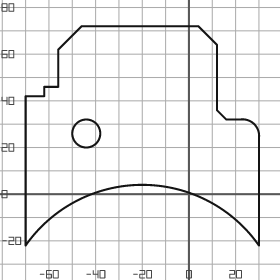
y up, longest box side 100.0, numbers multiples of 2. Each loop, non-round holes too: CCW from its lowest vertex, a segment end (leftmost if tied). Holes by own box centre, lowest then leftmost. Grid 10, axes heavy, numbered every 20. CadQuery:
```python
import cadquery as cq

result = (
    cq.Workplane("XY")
    .moveTo(-70.0, -22.0)
    .threePointArc((-20.0, 4.0), (30.0, -22.0))
    .lineTo(30.0, 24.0)
    .threePointArc((28.0, 30.0), (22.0, 32.0))
    .lineTo(16.0, 32.0)
    .lineTo(12.0, 36.0)
    .lineTo(12.0, 64.0)
    .lineTo(4.0, 72.0)
    .lineTo(-46.0, 72.0)
    .lineTo(-56.0, 62.0)
    .lineTo(-56.0, 46.0)
    .lineTo(-62.0, 46.0)
    .lineTo(-62.0, 42.0)
    .lineTo(-70.0, 42.0)
    .close()
    .moveTo(-44.0, 26.0)
    .circle(6.0)
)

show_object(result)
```